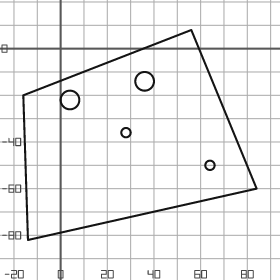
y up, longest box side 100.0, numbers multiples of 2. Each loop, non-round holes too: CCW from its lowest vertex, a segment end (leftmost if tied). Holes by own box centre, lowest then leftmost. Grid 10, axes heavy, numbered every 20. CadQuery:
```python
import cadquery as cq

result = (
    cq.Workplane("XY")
    .moveTo(-14.0, -82.0)
    .lineTo(84.0, -60.0)
    .lineTo(56.0, 8.0)
    .lineTo(-16.0, -20.0)
    .close()
    .moveTo(64.0, -50.0)
    .circle(2.0)
    .moveTo(28.0, -36.0)
    .circle(2.0)
    .moveTo(4.0, -22.0)
    .circle(4.0)
    .moveTo(36.0, -14.0)
    .circle(4.0)
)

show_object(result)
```